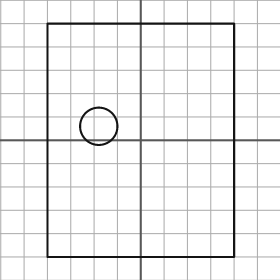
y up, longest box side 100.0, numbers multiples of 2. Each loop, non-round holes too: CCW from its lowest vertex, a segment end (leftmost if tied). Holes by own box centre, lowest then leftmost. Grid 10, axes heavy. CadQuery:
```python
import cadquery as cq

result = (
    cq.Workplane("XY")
    .moveTo(-40.0, -50.0)
    .lineTo(40.0, -50.0)
    .lineTo(40.0, 50.0)
    .lineTo(-40.0, 50.0)
    .close()
    .moveTo(-18.0, 6.0)
    .circle(8.0)
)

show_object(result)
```